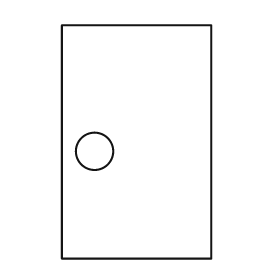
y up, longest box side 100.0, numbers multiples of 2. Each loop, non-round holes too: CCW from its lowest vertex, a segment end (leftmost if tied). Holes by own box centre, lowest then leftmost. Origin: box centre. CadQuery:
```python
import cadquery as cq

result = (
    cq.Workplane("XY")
    .moveTo(-32.0, -50.0)
    .lineTo(32.0, -50.0)
    .lineTo(32.0, 50.0)
    .lineTo(-32.0, 50.0)
    .close()
    .moveTo(-18.0, -4.0)
    .circle(8.0)
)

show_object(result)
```